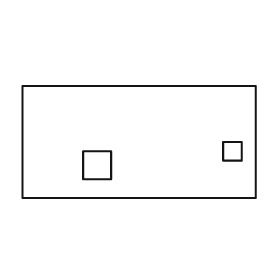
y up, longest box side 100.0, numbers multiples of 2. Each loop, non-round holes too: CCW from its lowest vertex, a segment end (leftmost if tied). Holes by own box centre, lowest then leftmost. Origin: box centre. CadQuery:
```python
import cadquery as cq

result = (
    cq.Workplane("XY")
    .moveTo(-50.0, -24.0)
    .lineTo(50.0, -24.0)
    .lineTo(50.0, 24.0)
    .lineTo(-50.0, 24.0)
    .close()
    .moveTo(-24.0, -16.0)
    .lineTo(-12.0, -16.0)
    .lineTo(-12.0, -4.0)
    .lineTo(-24.0, -4.0)
    .close()
    .moveTo(36.0, -8.0)
    .lineTo(44.0, -8.0)
    .lineTo(44.0, 0.0)
    .lineTo(36.0, 0.0)
    .close()
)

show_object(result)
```